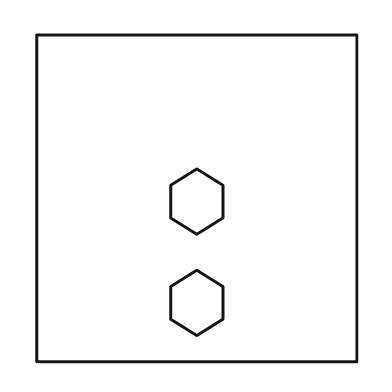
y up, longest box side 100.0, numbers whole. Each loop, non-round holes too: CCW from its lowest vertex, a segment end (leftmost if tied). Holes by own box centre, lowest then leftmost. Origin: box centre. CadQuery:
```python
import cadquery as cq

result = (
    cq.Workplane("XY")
    .moveTo(-49.0, -50.0)
    .lineTo(49.0, -50.0)
    .lineTo(49.0, 50.0)
    .lineTo(-49.0, 50.0)
    .close()
    .moveTo(0.0, -42.0)
    .lineTo(8.0, -37.0)
    .lineTo(8.0, -27.0)
    .lineTo(0.0, -22.0)
    .lineTo(-8.0, -27.0)
    .lineTo(-8.0, -37.0)
    .close()
    .moveTo(0.0, -11.0)
    .lineTo(8.0, -6.0)
    .lineTo(8.0, 4.0)
    .lineTo(0.0, 9.0)
    .lineTo(-8.0, 4.0)
    .lineTo(-8.0, -6.0)
    .close()
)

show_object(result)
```